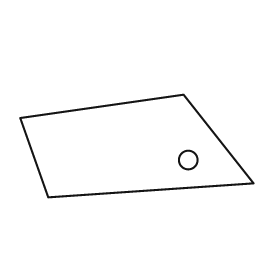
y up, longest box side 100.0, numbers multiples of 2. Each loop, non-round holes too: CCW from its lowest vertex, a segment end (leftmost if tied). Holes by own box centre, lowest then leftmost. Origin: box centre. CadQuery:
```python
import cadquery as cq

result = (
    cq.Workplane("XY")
    .moveTo(-38.0, -22.0)
    .lineTo(50.0, -16.0)
    .lineTo(20.0, 22.0)
    .lineTo(-50.0, 12.0)
    .close()
    .moveTo(22.0, -6.0)
    .circle(4.0)
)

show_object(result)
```